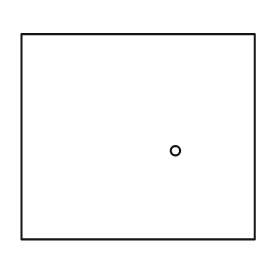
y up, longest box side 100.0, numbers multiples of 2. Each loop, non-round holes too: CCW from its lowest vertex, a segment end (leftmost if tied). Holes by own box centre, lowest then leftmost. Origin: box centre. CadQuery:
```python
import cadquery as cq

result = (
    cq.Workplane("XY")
    .moveTo(-50.0, -44.0)
    .lineTo(50.0, -44.0)
    .lineTo(50.0, 44.0)
    .lineTo(-50.0, 44.0)
    .close()
    .moveTo(16.0, -6.0)
    .circle(2.0)
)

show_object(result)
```